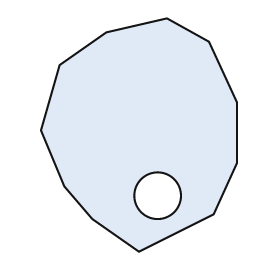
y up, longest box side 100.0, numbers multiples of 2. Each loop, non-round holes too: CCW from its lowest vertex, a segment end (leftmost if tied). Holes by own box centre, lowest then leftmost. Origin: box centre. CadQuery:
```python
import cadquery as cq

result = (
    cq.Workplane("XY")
    .moveTo(0.0, -50.0)
    .lineTo(32.0, -34.0)
    .lineTo(42.0, -12.0)
    .lineTo(42.0, 14.0)
    .lineTo(30.0, 40.0)
    .lineTo(12.0, 50.0)
    .lineTo(-14.0, 44.0)
    .lineTo(-34.0, 30.0)
    .lineTo(-42.0, 2.0)
    .lineTo(-32.0, -22.0)
    .lineTo(-20.0, -36.0)
    .close()
    .moveTo(8.0, -26.0)
    .circle(10.0)
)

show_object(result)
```